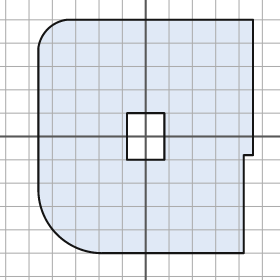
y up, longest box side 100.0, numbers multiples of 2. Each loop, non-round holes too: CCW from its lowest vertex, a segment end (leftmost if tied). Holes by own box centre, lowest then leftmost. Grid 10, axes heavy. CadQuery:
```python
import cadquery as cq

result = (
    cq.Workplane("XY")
    .moveTo(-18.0, -50.0)
    .lineTo(42.0, -50.0)
    .lineTo(42.0, -8.0)
    .lineTo(46.0, -8.0)
    .lineTo(46.0, 50.0)
    .lineTo(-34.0, 50.0)
    .threePointArc((-42.0, 46.0), (-46.0, 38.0))
    .lineTo(-46.0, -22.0)
    .threePointArc((-38.0, -42.0), (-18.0, -50.0))
    .close()
    .moveTo(-8.0, -10.0)
    .lineTo(8.0, -10.0)
    .lineTo(8.0, 10.0)
    .lineTo(-8.0, 10.0)
    .close()
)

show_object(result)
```